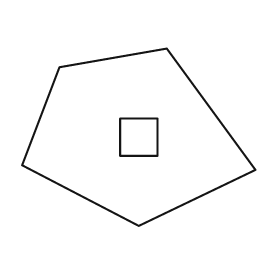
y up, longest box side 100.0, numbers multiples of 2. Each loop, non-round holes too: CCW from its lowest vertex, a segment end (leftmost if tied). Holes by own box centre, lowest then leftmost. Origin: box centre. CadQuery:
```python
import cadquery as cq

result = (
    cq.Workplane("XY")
    .moveTo(0.0, -38.0)
    .lineTo(50.0, -14.0)
    .lineTo(12.0, 38.0)
    .lineTo(-34.0, 30.0)
    .lineTo(-50.0, -12.0)
    .close()
    .moveTo(-8.0, -8.0)
    .lineTo(8.0, -8.0)
    .lineTo(8.0, 8.0)
    .lineTo(-8.0, 8.0)
    .close()
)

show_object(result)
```